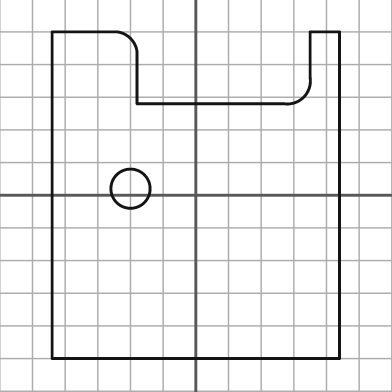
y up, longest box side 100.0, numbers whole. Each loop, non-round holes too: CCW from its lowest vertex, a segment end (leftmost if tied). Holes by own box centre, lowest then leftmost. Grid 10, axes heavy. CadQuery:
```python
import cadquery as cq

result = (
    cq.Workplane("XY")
    .moveTo(-44.0, -50.0)
    .lineTo(44.0, -50.0)
    .lineTo(44.0, 50.0)
    .lineTo(35.0, 50.0)
    .lineTo(35.0, 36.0)
    .threePointArc((33.0, 30.0), (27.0, 28.0))
    .lineTo(-18.0, 28.0)
    .lineTo(-18.0, 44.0)
    .threePointArc((-20.0, 48.0), (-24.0, 50.0))
    .lineTo(-44.0, 50.0)
    .close()
    .moveTo(-20.0, 2.0)
    .circle(6.0)
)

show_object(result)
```